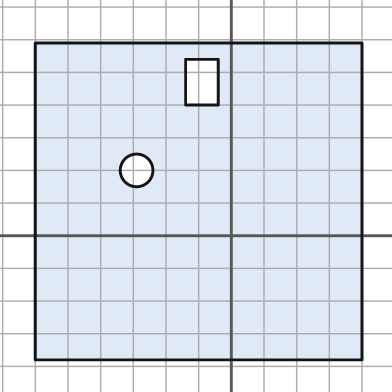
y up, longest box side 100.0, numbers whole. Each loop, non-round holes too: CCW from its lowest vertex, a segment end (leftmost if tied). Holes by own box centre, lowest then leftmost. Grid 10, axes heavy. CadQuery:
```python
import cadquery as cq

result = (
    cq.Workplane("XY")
    .moveTo(-60.0, -38.0)
    .lineTo(40.0, -38.0)
    .lineTo(40.0, 59.0)
    .lineTo(-60.0, 59.0)
    .close()
    .moveTo(-29.0, 20.0)
    .circle(5.0)
    .moveTo(-14.0, 40.0)
    .lineTo(-4.0, 40.0)
    .lineTo(-4.0, 54.0)
    .lineTo(-14.0, 54.0)
    .close()
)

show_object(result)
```